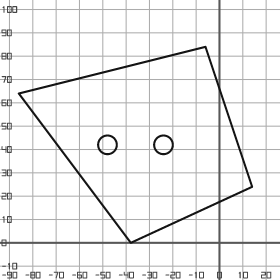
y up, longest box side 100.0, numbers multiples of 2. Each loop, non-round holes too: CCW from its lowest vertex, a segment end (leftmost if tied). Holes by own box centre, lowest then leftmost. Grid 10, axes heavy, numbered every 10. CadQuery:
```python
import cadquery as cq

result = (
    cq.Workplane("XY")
    .moveTo(-38.0, 0.0)
    .lineTo(14.0, 24.0)
    .lineTo(-6.0, 84.0)
    .lineTo(-86.0, 64.0)
    .close()
    .moveTo(-48.0, 42.0)
    .circle(4.0)
    .moveTo(-24.0, 42.0)
    .circle(4.0)
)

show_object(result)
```